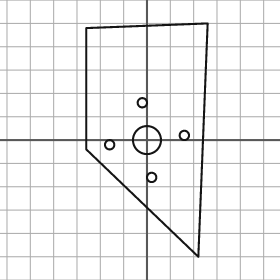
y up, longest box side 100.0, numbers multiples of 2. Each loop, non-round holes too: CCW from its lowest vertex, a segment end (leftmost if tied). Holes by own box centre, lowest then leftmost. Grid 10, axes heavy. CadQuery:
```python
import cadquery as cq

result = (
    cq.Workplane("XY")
    .moveTo(22.0, -50.0)
    .lineTo(26.0, 50.0)
    .lineTo(-26.0, 48.0)
    .lineTo(-26.0, -4.0)
    .close()
    .moveTo(2.0, -16.0)
    .circle(2.0)
    .moveTo(-16.0, -2.0)
    .circle(2.0)
    .moveTo(0.0, 0.0)
    .circle(6.0)
    .moveTo(16.0, 2.0)
    .circle(2.0)
    .moveTo(-2.0, 16.0)
    .circle(2.0)
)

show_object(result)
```